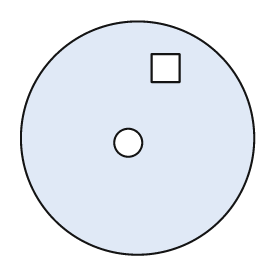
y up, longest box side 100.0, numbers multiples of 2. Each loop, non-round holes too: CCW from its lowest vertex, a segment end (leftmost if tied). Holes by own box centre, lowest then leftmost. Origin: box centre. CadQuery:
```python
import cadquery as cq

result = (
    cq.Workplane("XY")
    .moveTo(0.0, 0.0)
    .circle(50.0)
    .moveTo(-4.0, -2.0)
    .circle(6.0)
    .moveTo(6.0, 24.0)
    .lineTo(18.0, 24.0)
    .lineTo(18.0, 36.0)
    .lineTo(6.0, 36.0)
    .close()
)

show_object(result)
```